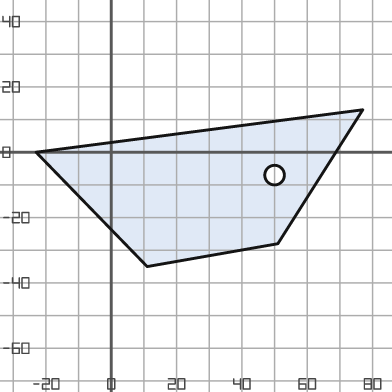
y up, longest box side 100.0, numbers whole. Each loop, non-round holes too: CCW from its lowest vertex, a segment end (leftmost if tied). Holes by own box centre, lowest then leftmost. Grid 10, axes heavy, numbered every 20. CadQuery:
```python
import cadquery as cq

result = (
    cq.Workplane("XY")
    .moveTo(11.0, -35.0)
    .lineTo(51.0, -28.0)
    .lineTo(77.0, 13.0)
    .lineTo(-23.0, 0.0)
    .close()
    .moveTo(50.0, -7.0)
    .circle(3.0)
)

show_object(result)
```